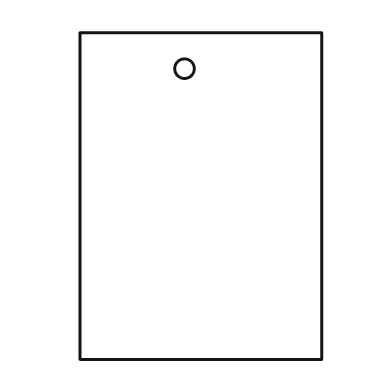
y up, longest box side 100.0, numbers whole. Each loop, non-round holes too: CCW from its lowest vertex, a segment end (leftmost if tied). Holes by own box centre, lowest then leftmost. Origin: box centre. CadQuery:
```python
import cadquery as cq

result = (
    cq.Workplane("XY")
    .moveTo(-37.0, -50.0)
    .lineTo(37.0, -50.0)
    .lineTo(37.0, 50.0)
    .lineTo(-37.0, 50.0)
    .close()
    .moveTo(-5.0, 39.0)
    .circle(3.0)
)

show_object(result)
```